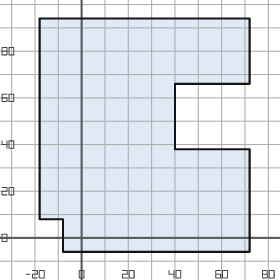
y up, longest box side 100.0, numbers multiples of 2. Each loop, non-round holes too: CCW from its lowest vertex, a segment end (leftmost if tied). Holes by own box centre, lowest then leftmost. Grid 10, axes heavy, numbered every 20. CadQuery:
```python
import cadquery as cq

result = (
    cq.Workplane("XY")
    .moveTo(-8.0, -6.0)
    .lineTo(72.0, -6.0)
    .lineTo(72.0, 38.0)
    .lineTo(40.0, 38.0)
    .lineTo(40.0, 66.0)
    .lineTo(72.0, 66.0)
    .lineTo(72.0, 94.0)
    .lineTo(-18.0, 94.0)
    .lineTo(-18.0, 8.0)
    .lineTo(-8.0, 8.0)
    .close()
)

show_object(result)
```